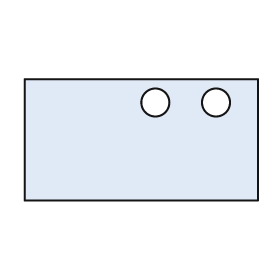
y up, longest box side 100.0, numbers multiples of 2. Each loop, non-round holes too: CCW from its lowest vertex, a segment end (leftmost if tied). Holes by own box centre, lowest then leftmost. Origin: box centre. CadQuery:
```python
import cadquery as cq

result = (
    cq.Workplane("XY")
    .moveTo(-50.0, -26.0)
    .lineTo(50.0, -26.0)
    .lineTo(50.0, 26.0)
    .lineTo(-50.0, 26.0)
    .close()
    .moveTo(6.0, 16.0)
    .circle(6.0)
    .moveTo(32.0, 16.0)
    .circle(6.0)
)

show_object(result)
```